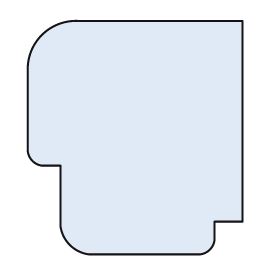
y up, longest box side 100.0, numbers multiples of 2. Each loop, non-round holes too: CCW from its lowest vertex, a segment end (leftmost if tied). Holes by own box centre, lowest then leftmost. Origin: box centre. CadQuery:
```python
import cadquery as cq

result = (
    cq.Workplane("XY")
    .moveTo(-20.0, -50.0)
    .lineTo(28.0, -50.0)
    .threePointArc((32.0, -48.0), (34.0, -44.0))
    .lineTo(34.0, -36.0)
    .lineTo(46.0, -36.0)
    .lineTo(46.0, 50.0)
    .lineTo(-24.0, 50.0)
    .threePointArc((-40.0, 44.0), (-46.0, 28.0))
    .lineTo(-46.0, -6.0)
    .threePointArc((-44.0, -10.0), (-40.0, -12.0))
    .lineTo(-32.0, -12.0)
    .lineTo(-32.0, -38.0)
    .threePointArc((-28.0, -46.0), (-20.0, -50.0))
    .close()
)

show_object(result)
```